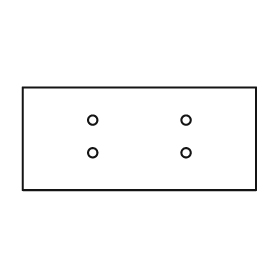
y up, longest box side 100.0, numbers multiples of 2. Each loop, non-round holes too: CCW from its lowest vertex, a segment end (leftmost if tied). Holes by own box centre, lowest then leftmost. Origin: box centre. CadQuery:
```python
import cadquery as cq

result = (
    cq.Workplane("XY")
    .moveTo(-50.0, -22.0)
    .lineTo(50.0, -22.0)
    .lineTo(50.0, 22.0)
    .lineTo(-50.0, 22.0)
    .close()
    .moveTo(-20.0, -6.0)
    .circle(2.0)
    .moveTo(20.0, -6.0)
    .circle(2.0)
    .moveTo(-20.0, 8.0)
    .circle(2.0)
    .moveTo(20.0, 8.0)
    .circle(2.0)
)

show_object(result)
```